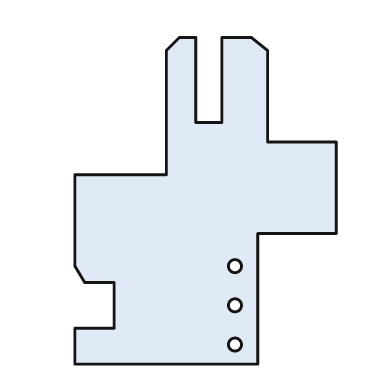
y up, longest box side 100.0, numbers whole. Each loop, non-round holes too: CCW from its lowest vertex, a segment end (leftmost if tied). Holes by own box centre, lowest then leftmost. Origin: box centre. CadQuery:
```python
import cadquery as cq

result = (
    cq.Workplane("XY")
    .moveTo(-40.0, -50.0)
    .lineTo(16.0, -50.0)
    .lineTo(16.0, -10.0)
    .lineTo(40.0, -10.0)
    .lineTo(40.0, 18.0)
    .lineTo(19.0, 18.0)
    .lineTo(19.0, 46.0)
    .lineTo(14.0, 50.0)
    .lineTo(5.0, 50.0)
    .lineTo(5.0, 24.0)
    .lineTo(-3.0, 24.0)
    .lineTo(-3.0, 50.0)
    .lineTo(-8.0, 50.0)
    .lineTo(-12.0, 46.0)
    .lineTo(-12.0, 8.0)
    .lineTo(-40.0, 8.0)
    .lineTo(-40.0, -20.0)
    .lineTo(-37.0, -25.0)
    .lineTo(-28.0, -25.0)
    .lineTo(-28.0, -39.0)
    .lineTo(-40.0, -39.0)
    .close()
    .moveTo(9.0, -44.0)
    .circle(2.0)
    .moveTo(9.0, -32.0)
    .circle(2.0)
    .moveTo(9.0, -20.0)
    .circle(2.0)
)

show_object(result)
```